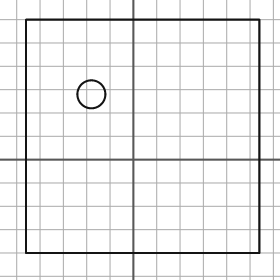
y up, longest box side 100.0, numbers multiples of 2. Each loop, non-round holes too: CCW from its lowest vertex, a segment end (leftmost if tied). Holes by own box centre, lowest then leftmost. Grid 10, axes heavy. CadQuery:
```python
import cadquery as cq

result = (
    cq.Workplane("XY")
    .moveTo(-46.0, -40.0)
    .lineTo(54.0, -40.0)
    .lineTo(54.0, 60.0)
    .lineTo(-46.0, 60.0)
    .close()
    .moveTo(-18.0, 28.0)
    .circle(6.0)
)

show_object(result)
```